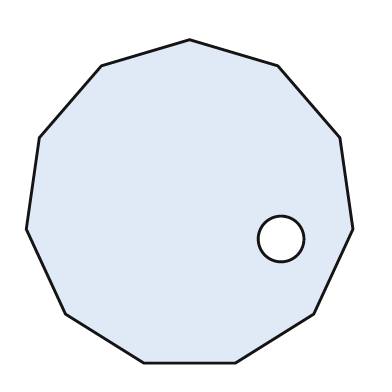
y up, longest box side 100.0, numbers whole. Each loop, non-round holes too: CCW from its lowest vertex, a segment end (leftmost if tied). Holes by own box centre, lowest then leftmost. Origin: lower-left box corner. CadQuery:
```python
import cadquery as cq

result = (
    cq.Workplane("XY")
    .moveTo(36.0, 0.0)
    .lineTo(64.0, 0.0)
    .lineTo(88.0, 15.0)
    .lineTo(100.0, 41.0)
    .lineTo(96.0, 69.0)
    .lineTo(77.0, 91.0)
    .lineTo(50.0, 99.0)
    .lineTo(23.0, 91.0)
    .lineTo(4.0, 69.0)
    .lineTo(0.0, 41.0)
    .lineTo(12.0, 15.0)
    .close()
    .moveTo(78.0, 38.0)
    .circle(7.0)
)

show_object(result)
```